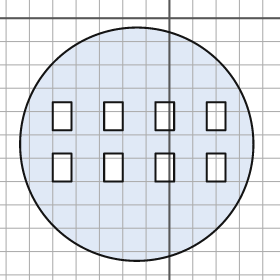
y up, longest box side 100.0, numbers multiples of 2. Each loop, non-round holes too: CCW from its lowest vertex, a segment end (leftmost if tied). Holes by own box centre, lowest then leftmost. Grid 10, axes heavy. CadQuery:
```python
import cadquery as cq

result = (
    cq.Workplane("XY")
    .moveTo(-14.0, -54.0)
    .circle(50.0)
    .moveTo(-50.0, -70.0)
    .lineTo(-42.0, -70.0)
    .lineTo(-42.0, -58.0)
    .lineTo(-50.0, -58.0)
    .close()
    .moveTo(-28.0, -70.0)
    .lineTo(-20.0, -70.0)
    .lineTo(-20.0, -58.0)
    .lineTo(-28.0, -58.0)
    .close()
    .moveTo(-6.0, -70.0)
    .lineTo(2.0, -70.0)
    .lineTo(2.0, -58.0)
    .lineTo(-6.0, -58.0)
    .close()
    .moveTo(16.0, -70.0)
    .lineTo(24.0, -70.0)
    .lineTo(24.0, -58.0)
    .lineTo(16.0, -58.0)
    .close()
    .moveTo(-50.0, -48.0)
    .lineTo(-42.0, -48.0)
    .lineTo(-42.0, -36.0)
    .lineTo(-50.0, -36.0)
    .close()
    .moveTo(-28.0, -48.0)
    .lineTo(-20.0, -48.0)
    .lineTo(-20.0, -36.0)
    .lineTo(-28.0, -36.0)
    .close()
    .moveTo(-6.0, -48.0)
    .lineTo(2.0, -48.0)
    .lineTo(2.0, -36.0)
    .lineTo(-6.0, -36.0)
    .close()
    .moveTo(16.0, -48.0)
    .lineTo(24.0, -48.0)
    .lineTo(24.0, -36.0)
    .lineTo(16.0, -36.0)
    .close()
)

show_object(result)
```